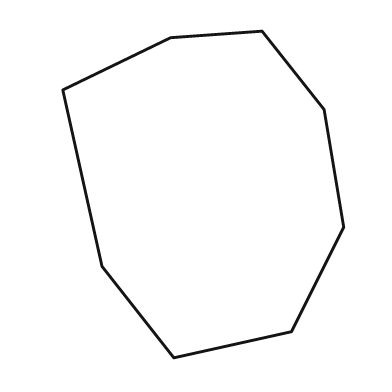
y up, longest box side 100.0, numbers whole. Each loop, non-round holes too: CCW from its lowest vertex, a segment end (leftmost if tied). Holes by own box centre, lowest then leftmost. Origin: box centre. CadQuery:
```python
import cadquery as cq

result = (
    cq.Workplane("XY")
    .moveTo(-9.0, -50.0)
    .lineTo(27.0, -42.0)
    .lineTo(43.0, -10.0)
    .lineTo(37.0, 26.0)
    .lineTo(18.0, 50.0)
    .lineTo(-10.0, 48.0)
    .lineTo(-43.0, 32.0)
    .lineTo(-31.0, -22.0)
    .close()
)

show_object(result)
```